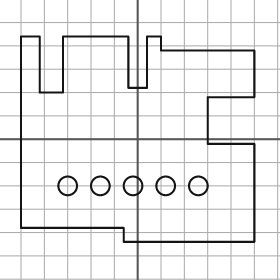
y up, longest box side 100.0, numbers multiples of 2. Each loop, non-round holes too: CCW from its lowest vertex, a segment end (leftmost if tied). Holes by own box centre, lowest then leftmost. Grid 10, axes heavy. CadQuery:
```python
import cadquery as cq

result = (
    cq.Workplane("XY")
    .moveTo(-6.0, -44.0)
    .lineTo(50.0, -44.0)
    .lineTo(50.0, -2.0)
    .lineTo(30.0, -2.0)
    .lineTo(30.0, 18.0)
    .lineTo(50.0, 18.0)
    .lineTo(50.0, 38.0)
    .lineTo(10.0, 38.0)
    .lineTo(10.0, 44.0)
    .lineTo(4.0, 44.0)
    .lineTo(4.0, 22.0)
    .lineTo(-4.0, 22.0)
    .lineTo(-4.0, 44.0)
    .lineTo(-32.0, 44.0)
    .lineTo(-32.0, 20.0)
    .lineTo(-42.0, 20.0)
    .lineTo(-42.0, 44.0)
    .lineTo(-50.0, 44.0)
    .lineTo(-50.0, -38.0)
    .lineTo(-6.0, -38.0)
    .close()
    .moveTo(-30.0, -20.0)
    .circle(4.0)
    .moveTo(-16.0, -20.0)
    .circle(4.0)
    .moveTo(-2.0, -20.0)
    .circle(4.0)
    .moveTo(12.0, -20.0)
    .circle(4.0)
    .moveTo(26.0, -20.0)
    .circle(4.0)
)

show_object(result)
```